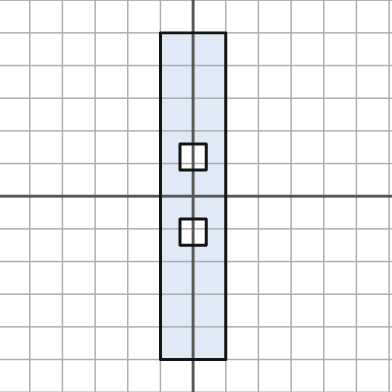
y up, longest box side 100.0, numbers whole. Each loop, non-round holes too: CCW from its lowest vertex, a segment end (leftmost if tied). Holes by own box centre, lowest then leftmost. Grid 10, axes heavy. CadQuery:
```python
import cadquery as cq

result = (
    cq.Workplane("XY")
    .moveTo(-10.0, -50.0)
    .lineTo(10.0, -50.0)
    .lineTo(10.0, 50.0)
    .lineTo(-10.0, 50.0)
    .close()
    .moveTo(-4.0, -15.0)
    .lineTo(4.0, -15.0)
    .lineTo(4.0, -7.0)
    .lineTo(-4.0, -7.0)
    .close()
    .moveTo(-4.0, 8.0)
    .lineTo(4.0, 8.0)
    .lineTo(4.0, 16.0)
    .lineTo(-4.0, 16.0)
    .close()
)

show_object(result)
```